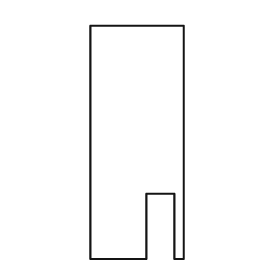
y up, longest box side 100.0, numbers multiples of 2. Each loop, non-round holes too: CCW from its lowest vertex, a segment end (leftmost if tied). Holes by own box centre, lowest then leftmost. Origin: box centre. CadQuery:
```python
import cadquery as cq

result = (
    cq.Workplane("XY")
    .moveTo(-20.0, -50.0)
    .lineTo(4.0, -50.0)
    .lineTo(4.0, -22.0)
    .lineTo(16.0, -22.0)
    .lineTo(16.0, -50.0)
    .lineTo(20.0, -50.0)
    .lineTo(20.0, 50.0)
    .lineTo(-20.0, 50.0)
    .close()
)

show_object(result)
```